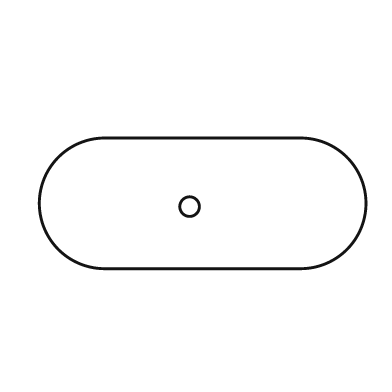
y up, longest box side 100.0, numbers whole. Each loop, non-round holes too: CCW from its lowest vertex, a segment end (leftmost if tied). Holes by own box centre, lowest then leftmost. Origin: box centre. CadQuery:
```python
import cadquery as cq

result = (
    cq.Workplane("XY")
    .moveTo(-30.0, -20.0)
    .lineTo(30.0, -20.0)
    .threePointArc((50.0, 0.0), (30.0, 20.0))
    .lineTo(-30.0, 20.0)
    .threePointArc((-50.0, 0.0), (-30.0, -20.0))
    .close()
    .moveTo(-4.0, -1.0)
    .circle(3.0)
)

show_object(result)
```